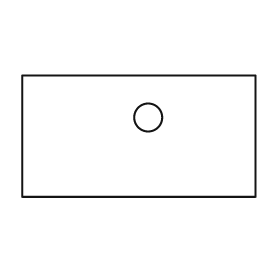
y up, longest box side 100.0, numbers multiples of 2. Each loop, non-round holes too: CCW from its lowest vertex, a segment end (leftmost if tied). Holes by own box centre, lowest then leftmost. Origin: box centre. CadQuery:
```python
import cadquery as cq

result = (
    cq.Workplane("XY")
    .moveTo(-50.0, -26.0)
    .lineTo(50.0, -26.0)
    .lineTo(50.0, 26.0)
    .lineTo(-50.0, 26.0)
    .close()
    .moveTo(4.0, 8.0)
    .circle(6.0)
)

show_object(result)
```